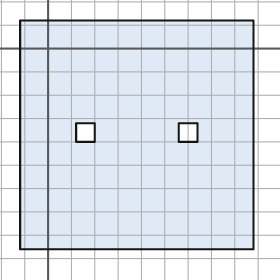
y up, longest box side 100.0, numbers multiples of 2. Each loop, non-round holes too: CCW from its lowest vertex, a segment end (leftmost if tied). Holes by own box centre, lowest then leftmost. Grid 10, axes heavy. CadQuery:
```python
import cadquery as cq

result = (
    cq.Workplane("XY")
    .moveTo(-12.0, -86.0)
    .lineTo(88.0, -86.0)
    .lineTo(88.0, 12.0)
    .lineTo(-12.0, 12.0)
    .close()
    .moveTo(12.0, -40.0)
    .lineTo(20.0, -40.0)
    .lineTo(20.0, -32.0)
    .lineTo(12.0, -32.0)
    .close()
    .moveTo(56.0, -40.0)
    .lineTo(64.0, -40.0)
    .lineTo(64.0, -32.0)
    .lineTo(56.0, -32.0)
    .close()
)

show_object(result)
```